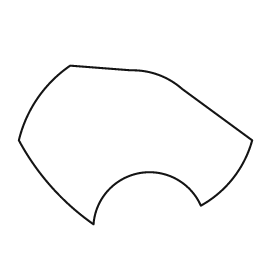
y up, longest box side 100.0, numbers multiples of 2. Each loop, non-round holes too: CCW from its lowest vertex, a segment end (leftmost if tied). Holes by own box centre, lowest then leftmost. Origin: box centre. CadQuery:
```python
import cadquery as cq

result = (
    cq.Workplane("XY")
    .moveTo(-18.0, -34.0)
    .threePointArc((2.0, -12.0), (28.0, -26.0))
    .threePointArc((42.0, -14.0), (50.0, 2.0))
    .lineTo(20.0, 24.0)
    .threePointArc((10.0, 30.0), (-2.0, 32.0))
    .lineTo(-28.0, 34.0)
    .threePointArc((-42.0, 20.0), (-50.0, 2.0))
    .threePointArc((-36.0, -18.0), (-18.0, -34.0))
    .close()
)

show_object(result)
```